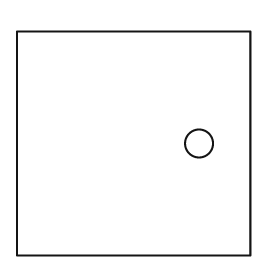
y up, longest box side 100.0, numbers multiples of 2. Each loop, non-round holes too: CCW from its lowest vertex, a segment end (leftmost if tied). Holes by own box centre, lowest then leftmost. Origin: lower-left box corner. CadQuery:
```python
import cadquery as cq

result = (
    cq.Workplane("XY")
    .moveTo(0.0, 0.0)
    .lineTo(100.0, 0.0)
    .lineTo(100.0, 96.0)
    .lineTo(0.0, 96.0)
    .close()
    .moveTo(78.0, 48.0)
    .circle(6.0)
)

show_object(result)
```